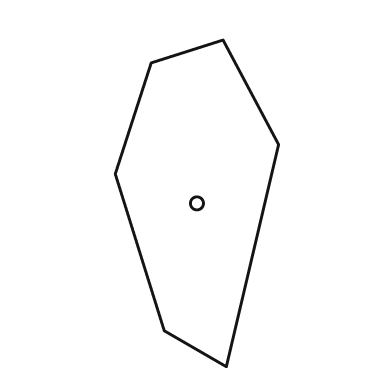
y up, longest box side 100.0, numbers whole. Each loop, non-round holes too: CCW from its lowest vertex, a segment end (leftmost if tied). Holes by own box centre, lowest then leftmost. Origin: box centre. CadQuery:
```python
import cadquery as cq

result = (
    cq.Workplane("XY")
    .moveTo(9.0, -50.0)
    .lineTo(25.0, 18.0)
    .lineTo(8.0, 50.0)
    .lineTo(-14.0, 43.0)
    .lineTo(-25.0, 9.0)
    .lineTo(-10.0, -39.0)
    .close()
    .moveTo(0.0, 0.0)
    .circle(2.0)
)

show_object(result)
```